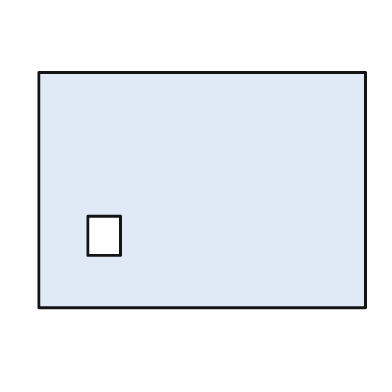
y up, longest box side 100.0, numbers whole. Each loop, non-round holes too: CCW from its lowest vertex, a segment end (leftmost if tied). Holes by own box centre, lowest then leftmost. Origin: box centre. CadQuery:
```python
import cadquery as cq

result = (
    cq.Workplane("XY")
    .moveTo(-50.0, -36.0)
    .lineTo(50.0, -36.0)
    .lineTo(50.0, 36.0)
    .lineTo(-50.0, 36.0)
    .close()
    .moveTo(-35.0, -20.0)
    .lineTo(-25.0, -20.0)
    .lineTo(-25.0, -8.0)
    .lineTo(-35.0, -8.0)
    .close()
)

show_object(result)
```